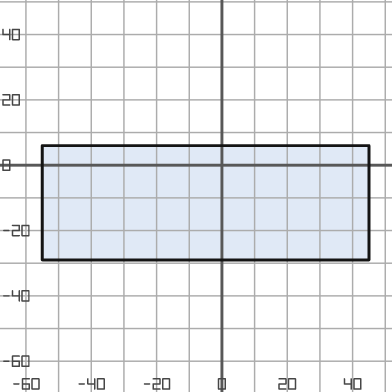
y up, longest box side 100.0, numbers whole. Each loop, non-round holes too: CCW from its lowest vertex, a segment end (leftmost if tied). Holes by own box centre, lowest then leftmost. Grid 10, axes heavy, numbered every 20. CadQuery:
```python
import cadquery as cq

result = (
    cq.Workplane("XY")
    .moveTo(-55.0, -29.0)
    .lineTo(45.0, -29.0)
    .lineTo(45.0, 6.0)
    .lineTo(-55.0, 6.0)
    .close()
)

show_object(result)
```